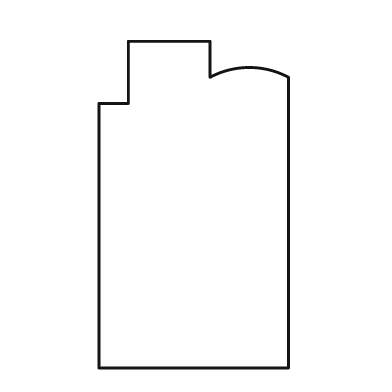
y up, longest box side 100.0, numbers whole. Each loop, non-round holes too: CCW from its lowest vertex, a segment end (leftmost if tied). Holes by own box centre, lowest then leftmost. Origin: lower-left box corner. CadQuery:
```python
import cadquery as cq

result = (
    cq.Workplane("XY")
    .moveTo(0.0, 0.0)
    .lineTo(58.0, 0.0)
    .lineTo(58.0, 89.0)
    .threePointArc((46.0, 92.0), (34.0, 89.0))
    .lineTo(34.0, 100.0)
    .lineTo(9.0, 100.0)
    .lineTo(9.0, 81.0)
    .lineTo(0.0, 81.0)
    .close()
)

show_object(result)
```